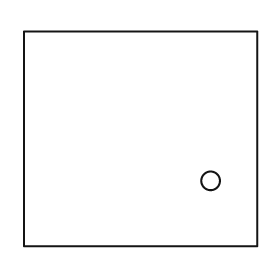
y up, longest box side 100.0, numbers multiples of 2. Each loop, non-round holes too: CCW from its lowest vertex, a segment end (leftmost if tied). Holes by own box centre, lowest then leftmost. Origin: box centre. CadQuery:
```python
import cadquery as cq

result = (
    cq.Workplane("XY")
    .moveTo(-50.0, -46.0)
    .lineTo(50.0, -46.0)
    .lineTo(50.0, 46.0)
    .lineTo(-50.0, 46.0)
    .close()
    .moveTo(30.0, -18.0)
    .circle(4.0)
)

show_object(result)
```